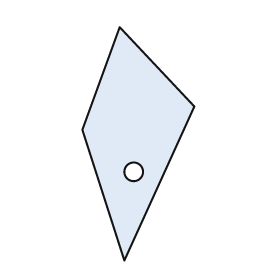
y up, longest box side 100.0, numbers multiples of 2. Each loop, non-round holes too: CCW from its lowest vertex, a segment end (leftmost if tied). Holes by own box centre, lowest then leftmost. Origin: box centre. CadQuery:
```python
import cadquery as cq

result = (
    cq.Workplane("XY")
    .moveTo(-6.0, -50.0)
    .lineTo(24.0, 16.0)
    .lineTo(-8.0, 50.0)
    .lineTo(-24.0, 6.0)
    .close()
    .moveTo(-2.0, -12.0)
    .circle(4.0)
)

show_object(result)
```